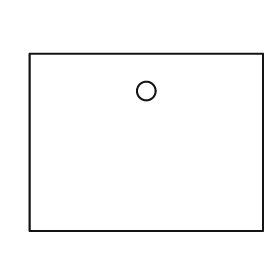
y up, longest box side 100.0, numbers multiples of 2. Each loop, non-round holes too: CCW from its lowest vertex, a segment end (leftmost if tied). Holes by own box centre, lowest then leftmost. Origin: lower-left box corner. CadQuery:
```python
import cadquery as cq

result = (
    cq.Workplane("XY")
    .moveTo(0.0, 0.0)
    .lineTo(100.0, 0.0)
    .lineTo(100.0, 76.0)
    .lineTo(0.0, 76.0)
    .close()
    .moveTo(50.0, 60.0)
    .circle(4.0)
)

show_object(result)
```